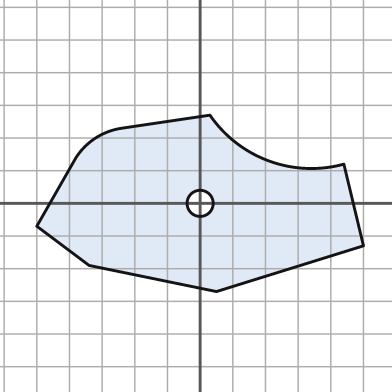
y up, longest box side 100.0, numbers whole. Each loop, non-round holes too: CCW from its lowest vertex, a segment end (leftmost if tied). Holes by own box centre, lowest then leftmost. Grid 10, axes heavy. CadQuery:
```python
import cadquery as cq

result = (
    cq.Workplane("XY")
    .moveTo(5.0, -27.0)
    .lineTo(50.0, -13.0)
    .lineTo(44.0, 12.0)
    .threePointArc((21.0, 13.0), (3.0, 27.0))
    .lineTo(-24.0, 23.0)
    .threePointArc((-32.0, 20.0), (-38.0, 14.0))
    .lineTo(-50.0, -7.0)
    .lineTo(-34.0, -19.0)
    .close()
    .moveTo(0.0, 0.0)
    .circle(4.0)
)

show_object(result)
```